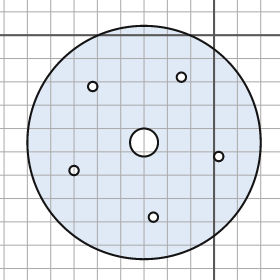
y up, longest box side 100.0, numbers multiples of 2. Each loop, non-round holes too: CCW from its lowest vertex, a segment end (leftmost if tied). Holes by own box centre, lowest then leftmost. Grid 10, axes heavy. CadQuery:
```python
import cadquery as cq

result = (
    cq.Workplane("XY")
    .moveTo(-30.0, -46.0)
    .circle(50.0)
    .moveTo(-26.0, -78.0)
    .circle(2.0)
    .moveTo(-60.0, -58.0)
    .circle(2.0)
    .moveTo(2.0, -52.0)
    .circle(2.0)
    .moveTo(-30.0, -46.0)
    .circle(6.0)
    .moveTo(-52.0, -22.0)
    .circle(2.0)
    .moveTo(-14.0, -18.0)
    .circle(2.0)
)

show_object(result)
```